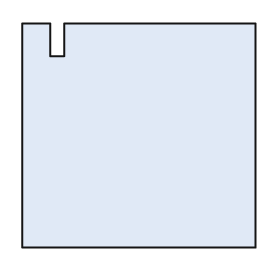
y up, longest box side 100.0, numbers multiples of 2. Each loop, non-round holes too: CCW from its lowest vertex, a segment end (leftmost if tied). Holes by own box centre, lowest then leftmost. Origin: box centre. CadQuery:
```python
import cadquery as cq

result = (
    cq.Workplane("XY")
    .moveTo(-50.0, -48.0)
    .lineTo(50.0, -48.0)
    .lineTo(50.0, 48.0)
    .lineTo(-32.0, 48.0)
    .lineTo(-32.0, 34.0)
    .lineTo(-38.0, 34.0)
    .lineTo(-38.0, 48.0)
    .lineTo(-50.0, 48.0)
    .close()
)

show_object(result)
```